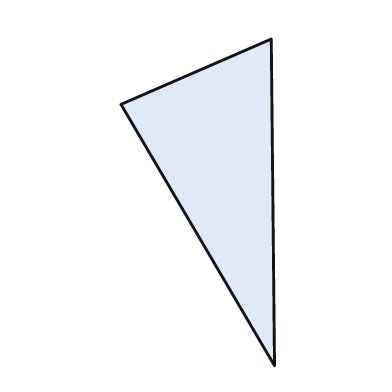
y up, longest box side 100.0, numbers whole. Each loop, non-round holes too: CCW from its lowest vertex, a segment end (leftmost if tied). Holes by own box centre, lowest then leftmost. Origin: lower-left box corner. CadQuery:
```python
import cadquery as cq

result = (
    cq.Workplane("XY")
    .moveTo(47.0, 0.0)
    .lineTo(46.0, 100.0)
    .lineTo(0.0, 80.0)
    .close()
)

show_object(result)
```